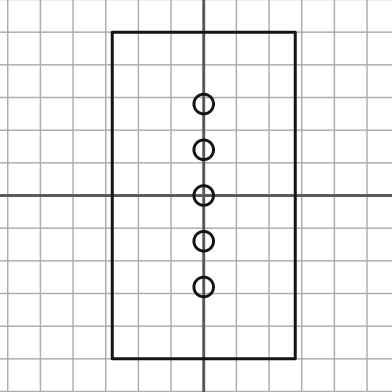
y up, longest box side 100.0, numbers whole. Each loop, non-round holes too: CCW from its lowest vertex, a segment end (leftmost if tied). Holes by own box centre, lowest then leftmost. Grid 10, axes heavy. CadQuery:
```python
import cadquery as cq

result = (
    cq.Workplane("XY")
    .moveTo(-28.0, -50.0)
    .lineTo(28.0, -50.0)
    .lineTo(28.0, 50.0)
    .lineTo(-28.0, 50.0)
    .close()
    .moveTo(0.0, -28.0)
    .circle(3.0)
    .moveTo(0.0, -14.0)
    .circle(3.0)
    .moveTo(0.0, 0.0)
    .circle(3.0)
    .moveTo(0.0, 14.0)
    .circle(3.0)
    .moveTo(0.0, 28.0)
    .circle(3.0)
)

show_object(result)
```